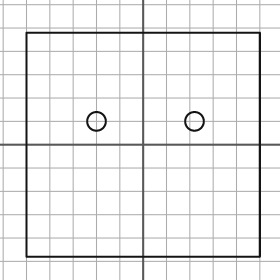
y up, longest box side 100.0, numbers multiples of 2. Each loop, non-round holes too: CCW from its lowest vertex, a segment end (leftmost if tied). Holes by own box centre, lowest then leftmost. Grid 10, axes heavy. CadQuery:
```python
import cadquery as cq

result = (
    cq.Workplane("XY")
    .moveTo(-50.0, -48.0)
    .lineTo(50.0, -48.0)
    .lineTo(50.0, 48.0)
    .lineTo(-50.0, 48.0)
    .close()
    .moveTo(-20.0, 10.0)
    .circle(4.0)
    .moveTo(22.0, 10.0)
    .circle(4.0)
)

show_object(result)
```